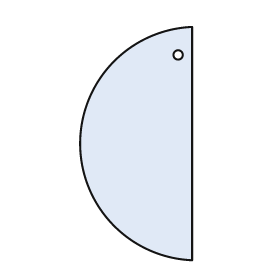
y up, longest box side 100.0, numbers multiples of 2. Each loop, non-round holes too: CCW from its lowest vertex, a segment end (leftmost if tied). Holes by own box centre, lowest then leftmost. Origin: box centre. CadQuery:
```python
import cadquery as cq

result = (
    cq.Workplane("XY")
    .moveTo(24.0, -50.0)
    .lineTo(24.0, 50.0)
    .threePointArc((-24.0, 0.0), (24.0, -50.0))
    .close()
    .moveTo(18.0, 38.0)
    .circle(2.0)
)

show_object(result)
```